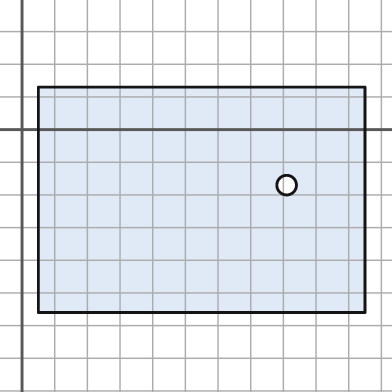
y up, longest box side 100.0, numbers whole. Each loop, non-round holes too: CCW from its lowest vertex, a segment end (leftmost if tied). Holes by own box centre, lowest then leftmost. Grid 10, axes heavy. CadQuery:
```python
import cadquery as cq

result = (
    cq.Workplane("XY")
    .moveTo(5.0, -56.0)
    .lineTo(105.0, -56.0)
    .lineTo(105.0, 13.0)
    .lineTo(5.0, 13.0)
    .close()
    .moveTo(81.0, -17.0)
    .circle(3.0)
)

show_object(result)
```